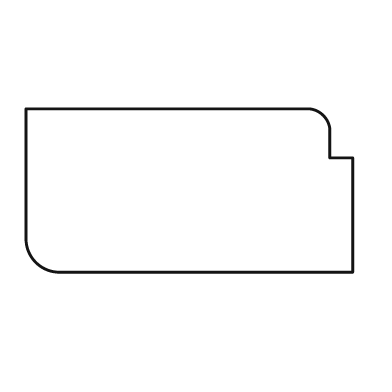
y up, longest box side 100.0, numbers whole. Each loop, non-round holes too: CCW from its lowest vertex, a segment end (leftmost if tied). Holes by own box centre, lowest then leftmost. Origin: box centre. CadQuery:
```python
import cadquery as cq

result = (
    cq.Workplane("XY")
    .moveTo(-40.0, -25.0)
    .lineTo(50.0, -25.0)
    .lineTo(50.0, 10.0)
    .lineTo(43.0, 10.0)
    .lineTo(43.0, 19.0)
    .threePointArc((41.0, 23.0), (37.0, 25.0))
    .lineTo(-50.0, 25.0)
    .lineTo(-50.0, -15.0)
    .threePointArc((-47.0, -22.0), (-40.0, -25.0))
    .close()
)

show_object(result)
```